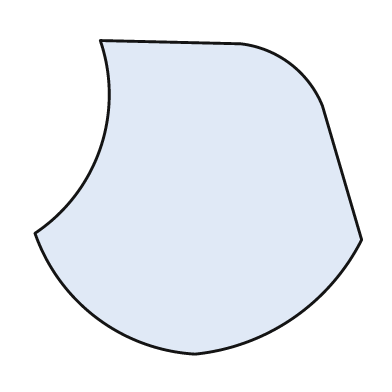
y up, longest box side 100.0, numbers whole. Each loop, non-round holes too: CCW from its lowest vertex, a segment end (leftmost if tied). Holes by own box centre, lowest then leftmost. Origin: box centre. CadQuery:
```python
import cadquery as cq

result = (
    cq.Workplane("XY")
    .moveTo(-1.0, -48.0)
    .threePointArc((29.0, -37.0), (50.0, -13.0))
    .lineTo(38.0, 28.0)
    .threePointArc((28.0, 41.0), (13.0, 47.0))
    .lineTo(-30.0, 48.0)
    .threePointArc((-30.0, 15.0), (-50.0, -11.0))
    .threePointArc((-31.0, -37.0), (-1.0, -48.0))
    .close()
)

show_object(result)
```